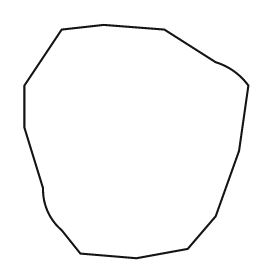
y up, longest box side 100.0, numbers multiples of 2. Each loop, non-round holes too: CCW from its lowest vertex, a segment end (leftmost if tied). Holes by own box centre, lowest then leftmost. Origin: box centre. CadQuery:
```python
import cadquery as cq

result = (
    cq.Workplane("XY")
    .moveTo(0.0, -50.0)
    .lineTo(22.0, -46.0)
    .lineTo(34.0, -32.0)
    .lineTo(44.0, -4.0)
    .lineTo(48.0, 24.0)
    .threePointArc((42.0, 30.0), (34.0, 34.0))
    .lineTo(12.0, 48.0)
    .lineTo(-14.0, 50.0)
    .lineTo(-32.0, 48.0)
    .lineTo(-48.0, 24.0)
    .lineTo(-48.0, 6.0)
    .lineTo(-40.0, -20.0)
    .threePointArc((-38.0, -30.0), (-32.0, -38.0))
    .lineTo(-24.0, -48.0)
    .close()
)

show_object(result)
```